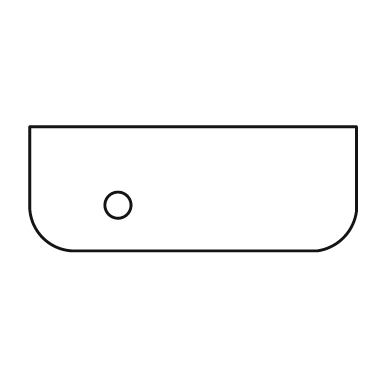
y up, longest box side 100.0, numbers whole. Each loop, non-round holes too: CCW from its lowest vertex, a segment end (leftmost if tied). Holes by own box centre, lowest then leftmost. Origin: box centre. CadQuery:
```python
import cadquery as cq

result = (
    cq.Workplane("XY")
    .moveTo(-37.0, -19.0)
    .lineTo(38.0, -19.0)
    .threePointArc((46.0, -15.0), (50.0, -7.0))
    .lineTo(50.0, 19.0)
    .lineTo(-50.0, 19.0)
    .lineTo(-50.0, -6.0)
    .threePointArc((-46.0, -15.0), (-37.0, -19.0))
    .close()
    .moveTo(-23.0, -5.0)
    .circle(4.0)
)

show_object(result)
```